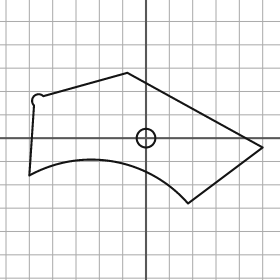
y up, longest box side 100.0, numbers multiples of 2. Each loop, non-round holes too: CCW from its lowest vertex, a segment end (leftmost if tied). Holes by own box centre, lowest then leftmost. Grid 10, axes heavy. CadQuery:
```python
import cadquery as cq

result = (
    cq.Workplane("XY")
    .moveTo(18.0, -28.0)
    .lineTo(50.0, -4.0)
    .lineTo(-8.0, 28.0)
    .lineTo(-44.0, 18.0)
    .threePointArc((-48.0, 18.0), (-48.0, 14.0))
    .lineTo(-50.0, -16.0)
    .threePointArc((-14.0, -10.0), (18.0, -28.0))
    .close()
    .moveTo(0.0, 0.0)
    .circle(4.0)
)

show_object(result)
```